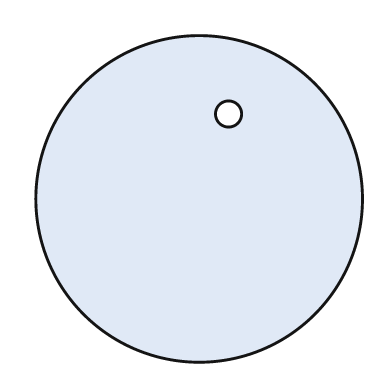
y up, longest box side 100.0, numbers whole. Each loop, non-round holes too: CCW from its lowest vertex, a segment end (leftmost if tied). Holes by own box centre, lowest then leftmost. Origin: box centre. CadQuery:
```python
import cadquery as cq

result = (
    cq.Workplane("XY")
    .moveTo(0.0, 0.0)
    .circle(50.0)
    .moveTo(9.0, 26.0)
    .circle(4.0)
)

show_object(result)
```